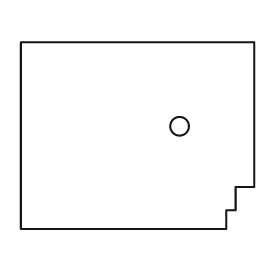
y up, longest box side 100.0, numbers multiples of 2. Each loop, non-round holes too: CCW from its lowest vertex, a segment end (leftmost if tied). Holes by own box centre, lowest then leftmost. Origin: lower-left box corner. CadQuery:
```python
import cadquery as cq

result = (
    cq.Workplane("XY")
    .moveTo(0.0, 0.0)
    .lineTo(88.0, 0.0)
    .lineTo(88.0, 8.0)
    .lineTo(92.0, 8.0)
    .lineTo(92.0, 18.0)
    .lineTo(100.0, 18.0)
    .lineTo(100.0, 80.0)
    .lineTo(0.0, 80.0)
    .close()
    .moveTo(68.0, 44.0)
    .circle(4.0)
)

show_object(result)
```